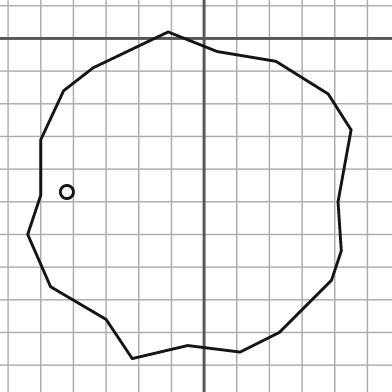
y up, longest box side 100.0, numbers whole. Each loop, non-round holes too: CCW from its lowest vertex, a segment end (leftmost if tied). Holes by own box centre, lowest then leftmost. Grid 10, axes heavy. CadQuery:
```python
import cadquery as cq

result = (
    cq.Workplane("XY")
    .moveTo(-22.0, -98.0)
    .lineTo(-5.0, -94.0)
    .lineTo(11.0, -96.0)
    .lineTo(23.0, -90.0)
    .lineTo(39.0, -74.0)
    .lineTo(42.0, -65.0)
    .lineTo(41.0, -50.0)
    .lineTo(45.0, -28.0)
    .lineTo(38.0, -17.0)
    .lineTo(22.0, -7.0)
    .lineTo(4.0, -4.0)
    .lineTo(-11.0, 2.0)
    .lineTo(-34.0, -9.0)
    .lineTo(-43.0, -16.0)
    .lineTo(-50.0, -31.0)
    .lineTo(-50.0, -48.0)
    .lineTo(-54.0, -60.0)
    .lineTo(-47.0, -76.0)
    .lineTo(-30.0, -86.0)
    .close()
    .moveTo(-42.0, -47.0)
    .circle(2.0)
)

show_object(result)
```